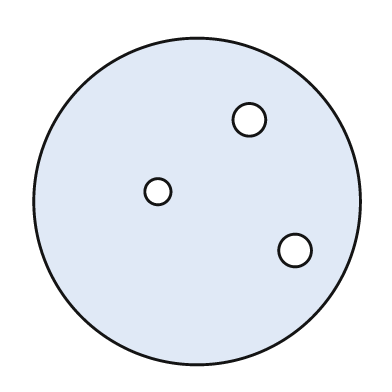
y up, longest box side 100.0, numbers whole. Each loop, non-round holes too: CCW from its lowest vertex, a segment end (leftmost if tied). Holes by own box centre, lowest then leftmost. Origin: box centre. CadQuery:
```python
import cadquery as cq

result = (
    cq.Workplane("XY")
    .moveTo(0.0, 0.0)
    .circle(50.0)
    .moveTo(30.0, -15.0)
    .circle(5.0)
    .moveTo(-12.0, 3.0)
    .circle(4.0)
    .moveTo(16.0, 25.0)
    .circle(5.0)
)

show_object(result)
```